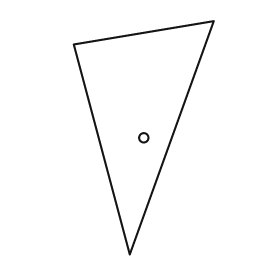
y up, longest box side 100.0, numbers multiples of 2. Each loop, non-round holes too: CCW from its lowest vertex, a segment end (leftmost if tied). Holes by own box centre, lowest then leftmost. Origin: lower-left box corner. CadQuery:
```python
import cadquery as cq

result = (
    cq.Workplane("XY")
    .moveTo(24.0, 0.0)
    .lineTo(60.0, 100.0)
    .lineTo(0.0, 90.0)
    .close()
    .moveTo(30.0, 50.0)
    .circle(2.0)
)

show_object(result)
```